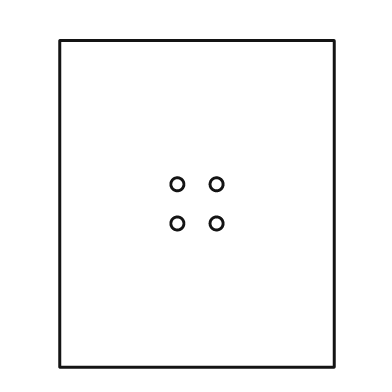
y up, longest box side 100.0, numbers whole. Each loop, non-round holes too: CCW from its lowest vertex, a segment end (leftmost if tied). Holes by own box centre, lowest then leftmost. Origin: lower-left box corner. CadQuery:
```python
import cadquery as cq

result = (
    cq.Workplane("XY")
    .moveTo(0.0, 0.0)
    .lineTo(84.0, 0.0)
    .lineTo(84.0, 100.0)
    .lineTo(0.0, 100.0)
    .close()
    .moveTo(36.0, 44.0)
    .circle(2.0)
    .moveTo(48.0, 44.0)
    .circle(2.0)
    .moveTo(36.0, 56.0)
    .circle(2.0)
    .moveTo(48.0, 56.0)
    .circle(2.0)
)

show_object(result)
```